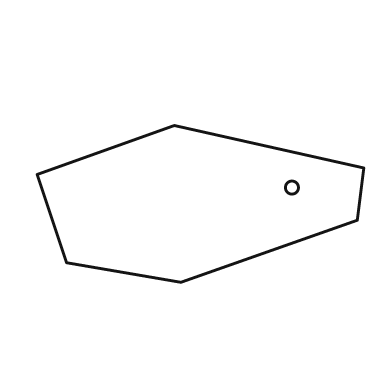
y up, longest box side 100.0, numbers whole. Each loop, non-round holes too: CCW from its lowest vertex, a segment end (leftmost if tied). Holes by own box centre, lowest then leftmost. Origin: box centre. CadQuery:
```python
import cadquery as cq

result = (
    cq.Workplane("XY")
    .moveTo(-6.0, -24.0)
    .lineTo(48.0, -5.0)
    .lineTo(50.0, 11.0)
    .lineTo(-8.0, 24.0)
    .lineTo(-50.0, 9.0)
    .lineTo(-41.0, -18.0)
    .close()
    .moveTo(28.0, 5.0)
    .circle(2.0)
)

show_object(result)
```